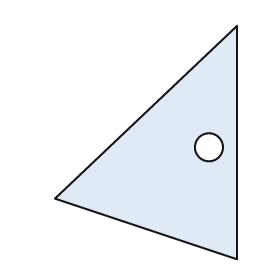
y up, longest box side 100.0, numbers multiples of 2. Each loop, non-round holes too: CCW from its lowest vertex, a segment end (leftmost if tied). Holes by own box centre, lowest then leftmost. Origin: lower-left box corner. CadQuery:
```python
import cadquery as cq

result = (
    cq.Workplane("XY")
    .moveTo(78.0, 0.0)
    .lineTo(78.0, 100.0)
    .lineTo(0.0, 26.0)
    .close()
    .moveTo(66.0, 48.0)
    .circle(6.0)
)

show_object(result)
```